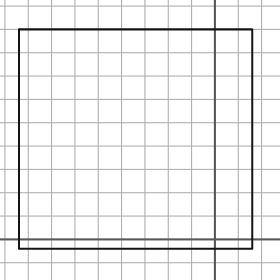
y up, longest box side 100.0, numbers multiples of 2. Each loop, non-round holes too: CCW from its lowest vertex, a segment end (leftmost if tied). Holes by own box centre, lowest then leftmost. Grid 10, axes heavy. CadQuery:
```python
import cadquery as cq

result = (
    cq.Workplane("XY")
    .moveTo(-84.0, -4.0)
    .lineTo(16.0, -4.0)
    .lineTo(16.0, 90.0)
    .lineTo(-84.0, 90.0)
    .close()
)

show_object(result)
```